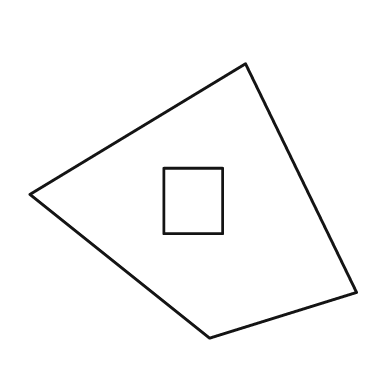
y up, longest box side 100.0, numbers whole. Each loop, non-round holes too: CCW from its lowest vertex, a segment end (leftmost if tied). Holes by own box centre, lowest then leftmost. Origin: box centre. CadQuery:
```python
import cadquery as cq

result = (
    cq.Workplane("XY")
    .moveTo(5.0, -42.0)
    .lineTo(50.0, -28.0)
    .lineTo(16.0, 42.0)
    .lineTo(-50.0, 2.0)
    .close()
    .moveTo(-9.0, -10.0)
    .lineTo(9.0, -10.0)
    .lineTo(9.0, 10.0)
    .lineTo(-9.0, 10.0)
    .close()
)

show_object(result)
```